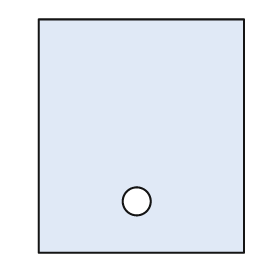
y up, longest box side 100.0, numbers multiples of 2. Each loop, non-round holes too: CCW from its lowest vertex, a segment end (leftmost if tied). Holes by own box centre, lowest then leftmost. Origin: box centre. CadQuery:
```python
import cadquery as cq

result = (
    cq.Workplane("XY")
    .moveTo(-44.0, -50.0)
    .lineTo(44.0, -50.0)
    .lineTo(44.0, 50.0)
    .lineTo(-44.0, 50.0)
    .close()
    .moveTo(-2.0, -28.0)
    .circle(6.0)
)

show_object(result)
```